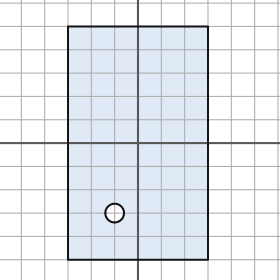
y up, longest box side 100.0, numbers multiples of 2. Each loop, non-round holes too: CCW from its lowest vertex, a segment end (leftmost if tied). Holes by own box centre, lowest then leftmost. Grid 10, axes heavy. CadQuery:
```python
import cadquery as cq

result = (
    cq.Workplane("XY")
    .moveTo(-30.0, -50.0)
    .lineTo(30.0, -50.0)
    .lineTo(30.0, 50.0)
    .lineTo(-30.0, 50.0)
    .close()
    .moveTo(-10.0, -30.0)
    .circle(4.0)
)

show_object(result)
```